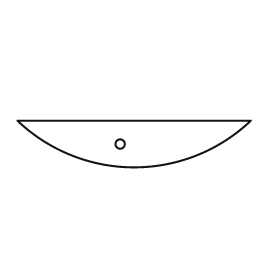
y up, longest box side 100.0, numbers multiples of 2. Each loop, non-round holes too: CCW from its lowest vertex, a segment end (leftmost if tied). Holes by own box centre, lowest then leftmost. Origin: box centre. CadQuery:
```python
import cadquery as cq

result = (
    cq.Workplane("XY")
    .moveTo(-50.0, 10.0)
    .threePointArc((0.0, -10.0), (50.0, 10.0))
    .close()
    .moveTo(-6.0, 0.0)
    .circle(2.0)
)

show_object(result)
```